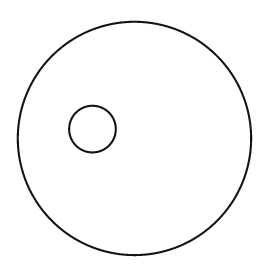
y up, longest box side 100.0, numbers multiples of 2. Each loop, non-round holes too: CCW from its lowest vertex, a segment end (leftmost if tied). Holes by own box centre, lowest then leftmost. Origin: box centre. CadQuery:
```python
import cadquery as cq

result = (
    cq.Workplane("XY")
    .moveTo(0.0, 0.0)
    .circle(50.0)
    .moveTo(-18.0, 4.0)
    .circle(10.0)
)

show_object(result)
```